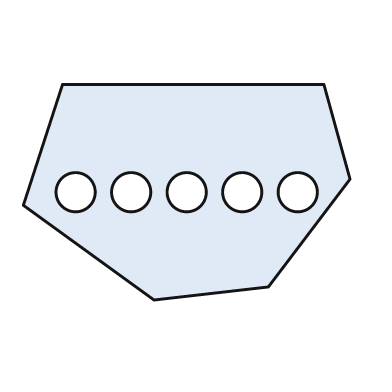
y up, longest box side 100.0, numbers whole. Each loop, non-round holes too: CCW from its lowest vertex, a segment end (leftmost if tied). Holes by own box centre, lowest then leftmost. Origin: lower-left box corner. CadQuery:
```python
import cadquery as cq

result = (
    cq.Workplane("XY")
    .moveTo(40.0, 0.0)
    .lineTo(75.0, 4.0)
    .lineTo(100.0, 37.0)
    .lineTo(92.0, 66.0)
    .lineTo(12.0, 66.0)
    .lineTo(0.0, 29.0)
    .close()
    .moveTo(16.0, 33.0)
    .circle(6.0)
    .moveTo(33.0, 33.0)
    .circle(6.0)
    .moveTo(50.0, 33.0)
    .circle(6.0)
    .moveTo(67.0, 33.0)
    .circle(6.0)
    .moveTo(84.0, 33.0)
    .circle(6.0)
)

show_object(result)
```